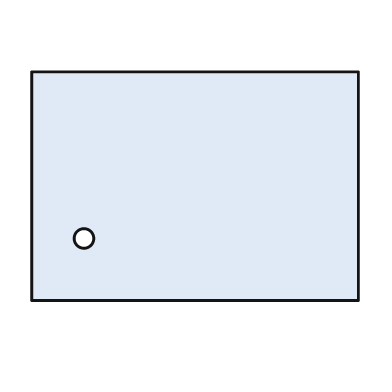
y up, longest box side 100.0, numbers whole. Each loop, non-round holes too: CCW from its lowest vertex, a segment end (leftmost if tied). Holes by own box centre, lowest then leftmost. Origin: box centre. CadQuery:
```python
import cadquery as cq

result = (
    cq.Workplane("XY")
    .moveTo(-50.0, -35.0)
    .lineTo(50.0, -35.0)
    .lineTo(50.0, 35.0)
    .lineTo(-50.0, 35.0)
    .close()
    .moveTo(-34.0, -16.0)
    .circle(3.0)
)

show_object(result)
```